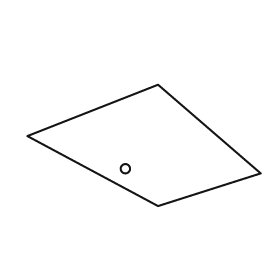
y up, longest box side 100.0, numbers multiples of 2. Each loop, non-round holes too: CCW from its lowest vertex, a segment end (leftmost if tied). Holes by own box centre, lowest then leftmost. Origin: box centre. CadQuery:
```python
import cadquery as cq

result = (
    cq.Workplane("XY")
    .moveTo(6.0, -26.0)
    .lineTo(50.0, -12.0)
    .lineTo(6.0, 26.0)
    .lineTo(-50.0, 4.0)
    .close()
    .moveTo(-8.0, -10.0)
    .circle(2.0)
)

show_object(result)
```